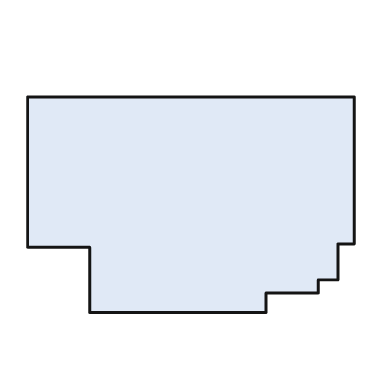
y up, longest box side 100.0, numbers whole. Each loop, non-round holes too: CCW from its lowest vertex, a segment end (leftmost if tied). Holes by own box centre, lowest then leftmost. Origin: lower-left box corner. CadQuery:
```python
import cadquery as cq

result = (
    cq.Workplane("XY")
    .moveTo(19.0, 0.0)
    .lineTo(73.0, 0.0)
    .lineTo(73.0, 6.0)
    .lineTo(89.0, 6.0)
    .lineTo(89.0, 10.0)
    .lineTo(95.0, 10.0)
    .lineTo(95.0, 21.0)
    .lineTo(100.0, 21.0)
    .lineTo(100.0, 66.0)
    .lineTo(0.0, 66.0)
    .lineTo(0.0, 20.0)
    .lineTo(19.0, 20.0)
    .close()
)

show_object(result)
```